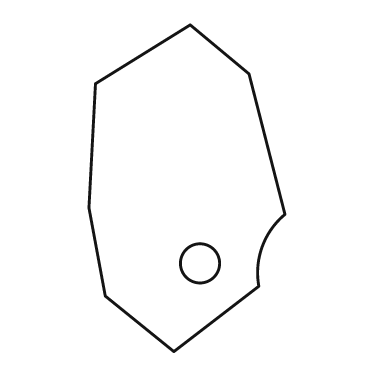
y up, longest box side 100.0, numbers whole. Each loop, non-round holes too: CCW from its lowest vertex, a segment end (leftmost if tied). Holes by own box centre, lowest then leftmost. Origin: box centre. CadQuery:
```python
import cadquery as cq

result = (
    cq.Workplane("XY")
    .moveTo(-4.0, -50.0)
    .lineTo(22.0, -30.0)
    .threePointArc((23.0, -18.0), (30.0, -8.0))
    .lineTo(19.0, 35.0)
    .lineTo(1.0, 50.0)
    .lineTo(-28.0, 32.0)
    .lineTo(-30.0, -6.0)
    .lineTo(-25.0, -33.0)
    .close()
    .moveTo(4.0, -23.0)
    .circle(6.0)
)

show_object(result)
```